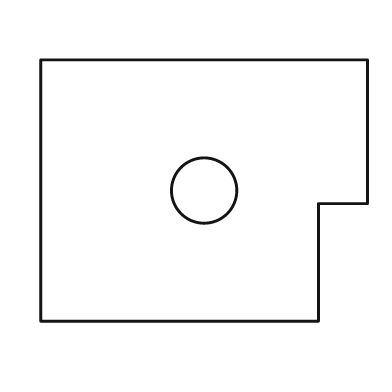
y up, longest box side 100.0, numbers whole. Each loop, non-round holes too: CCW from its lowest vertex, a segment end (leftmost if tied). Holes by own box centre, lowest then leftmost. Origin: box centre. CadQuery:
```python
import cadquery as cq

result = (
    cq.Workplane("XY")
    .moveTo(-50.0, -40.0)
    .lineTo(35.0, -40.0)
    .lineTo(35.0, -4.0)
    .lineTo(50.0, -4.0)
    .lineTo(50.0, 40.0)
    .lineTo(-50.0, 40.0)
    .close()
    .moveTo(0.0, 0.0)
    .circle(10.0)
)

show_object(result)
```